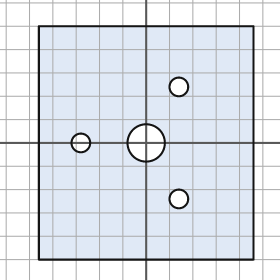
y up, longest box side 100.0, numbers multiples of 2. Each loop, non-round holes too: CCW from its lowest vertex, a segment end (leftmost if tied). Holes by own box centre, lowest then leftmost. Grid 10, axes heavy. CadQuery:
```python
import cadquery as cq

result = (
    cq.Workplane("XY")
    .moveTo(-46.0, -50.0)
    .lineTo(46.0, -50.0)
    .lineTo(46.0, 50.0)
    .lineTo(-46.0, 50.0)
    .close()
    .moveTo(14.0, -24.0)
    .circle(4.0)
    .moveTo(-28.0, 0.0)
    .circle(4.0)
    .moveTo(0.0, 0.0)
    .circle(8.0)
    .moveTo(14.0, 24.0)
    .circle(4.0)
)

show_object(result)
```